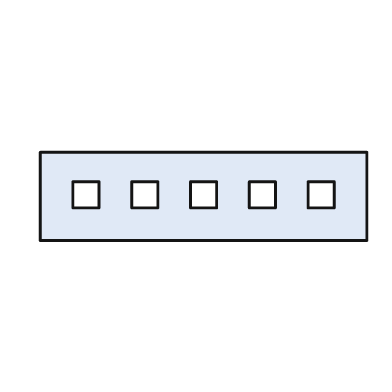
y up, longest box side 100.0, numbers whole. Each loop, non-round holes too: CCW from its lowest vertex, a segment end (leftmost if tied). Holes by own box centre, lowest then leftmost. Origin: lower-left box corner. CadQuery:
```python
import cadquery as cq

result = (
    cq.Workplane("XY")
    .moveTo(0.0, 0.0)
    .lineTo(100.0, 0.0)
    .lineTo(100.0, 27.0)
    .lineTo(0.0, 27.0)
    .close()
    .moveTo(10.0, 10.0)
    .lineTo(18.0, 10.0)
    .lineTo(18.0, 18.0)
    .lineTo(10.0, 18.0)
    .close()
    .moveTo(28.0, 10.0)
    .lineTo(36.0, 10.0)
    .lineTo(36.0, 18.0)
    .lineTo(28.0, 18.0)
    .close()
    .moveTo(46.0, 10.0)
    .lineTo(54.0, 10.0)
    .lineTo(54.0, 18.0)
    .lineTo(46.0, 18.0)
    .close()
    .moveTo(64.0, 10.0)
    .lineTo(72.0, 10.0)
    .lineTo(72.0, 18.0)
    .lineTo(64.0, 18.0)
    .close()
    .moveTo(82.0, 10.0)
    .lineTo(90.0, 10.0)
    .lineTo(90.0, 18.0)
    .lineTo(82.0, 18.0)
    .close()
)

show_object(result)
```